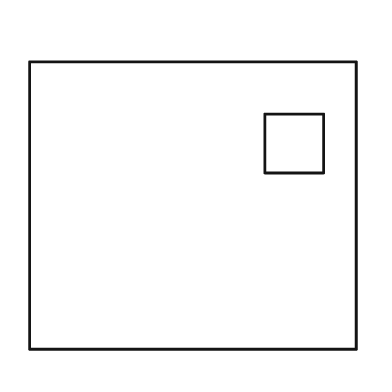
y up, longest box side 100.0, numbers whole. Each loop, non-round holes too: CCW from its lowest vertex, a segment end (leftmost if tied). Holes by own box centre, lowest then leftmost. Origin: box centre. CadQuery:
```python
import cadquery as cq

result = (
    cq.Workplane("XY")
    .moveTo(-50.0, -44.0)
    .lineTo(50.0, -44.0)
    .lineTo(50.0, 44.0)
    .lineTo(-50.0, 44.0)
    .close()
    .moveTo(22.0, 10.0)
    .lineTo(40.0, 10.0)
    .lineTo(40.0, 28.0)
    .lineTo(22.0, 28.0)
    .close()
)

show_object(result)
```